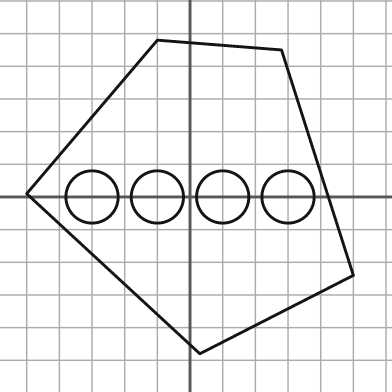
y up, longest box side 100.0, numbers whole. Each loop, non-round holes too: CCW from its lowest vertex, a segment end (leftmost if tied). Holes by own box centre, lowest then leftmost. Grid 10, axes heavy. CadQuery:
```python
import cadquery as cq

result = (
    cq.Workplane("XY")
    .moveTo(3.0, -48.0)
    .lineTo(50.0, -24.0)
    .lineTo(28.0, 45.0)
    .lineTo(-10.0, 48.0)
    .lineTo(-50.0, 1.0)
    .close()
    .moveTo(-30.0, 0.0)
    .circle(8.0)
    .moveTo(-10.0, 0.0)
    .circle(8.0)
    .moveTo(10.0, 0.0)
    .circle(8.0)
    .moveTo(30.0, 0.0)
    .circle(8.0)
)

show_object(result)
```